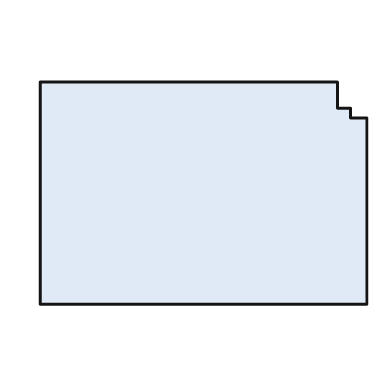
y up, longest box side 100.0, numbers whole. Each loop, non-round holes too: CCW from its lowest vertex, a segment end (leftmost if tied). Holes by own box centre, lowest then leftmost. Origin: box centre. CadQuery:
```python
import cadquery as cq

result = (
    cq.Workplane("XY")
    .moveTo(-50.0, -34.0)
    .lineTo(50.0, -34.0)
    .lineTo(50.0, 23.0)
    .lineTo(45.0, 23.0)
    .lineTo(45.0, 26.0)
    .lineTo(41.0, 26.0)
    .lineTo(41.0, 34.0)
    .lineTo(-50.0, 34.0)
    .close()
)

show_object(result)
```